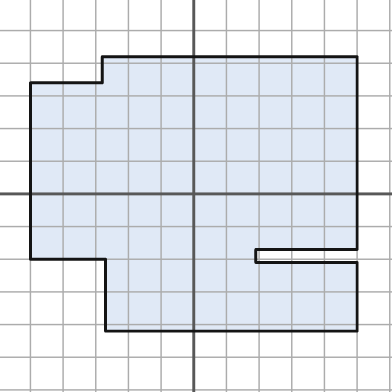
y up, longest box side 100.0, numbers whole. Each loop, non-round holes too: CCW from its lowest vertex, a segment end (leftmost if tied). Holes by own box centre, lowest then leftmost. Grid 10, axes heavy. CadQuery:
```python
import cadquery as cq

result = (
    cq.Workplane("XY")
    .moveTo(-27.0, -42.0)
    .lineTo(50.0, -42.0)
    .lineTo(50.0, -21.0)
    .lineTo(19.0, -21.0)
    .lineTo(19.0, -17.0)
    .lineTo(50.0, -17.0)
    .lineTo(50.0, 42.0)
    .lineTo(-28.0, 42.0)
    .lineTo(-28.0, 34.0)
    .lineTo(-50.0, 34.0)
    .lineTo(-50.0, -20.0)
    .lineTo(-27.0, -20.0)
    .close()
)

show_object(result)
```